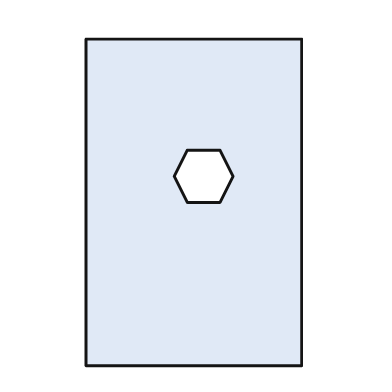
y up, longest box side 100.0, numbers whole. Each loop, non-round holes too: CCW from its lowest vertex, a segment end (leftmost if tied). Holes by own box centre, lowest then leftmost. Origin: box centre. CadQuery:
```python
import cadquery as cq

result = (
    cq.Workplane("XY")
    .moveTo(-33.0, -50.0)
    .lineTo(33.0, -50.0)
    .lineTo(33.0, 50.0)
    .lineTo(-33.0, 50.0)
    .close()
    .moveTo(-2.0, 0.0)
    .lineTo(8.0, 0.0)
    .lineTo(12.0, 8.0)
    .lineTo(8.0, 16.0)
    .lineTo(-2.0, 16.0)
    .lineTo(-6.0, 8.0)
    .close()
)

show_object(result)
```